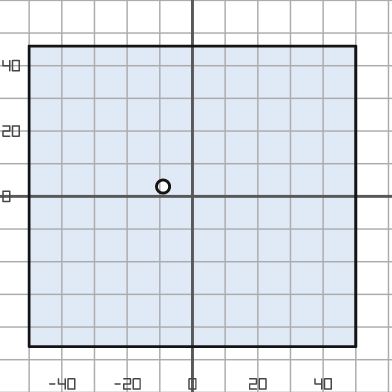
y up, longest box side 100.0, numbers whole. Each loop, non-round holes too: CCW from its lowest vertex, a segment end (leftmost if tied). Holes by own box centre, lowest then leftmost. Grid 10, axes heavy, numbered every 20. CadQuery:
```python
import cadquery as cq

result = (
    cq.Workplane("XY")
    .moveTo(-50.0, -46.0)
    .lineTo(50.0, -46.0)
    .lineTo(50.0, 46.0)
    .lineTo(-50.0, 46.0)
    .close()
    .moveTo(-9.0, 3.0)
    .circle(2.0)
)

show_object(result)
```